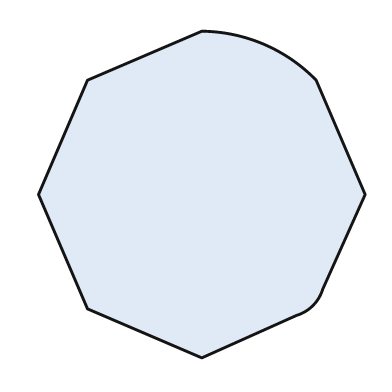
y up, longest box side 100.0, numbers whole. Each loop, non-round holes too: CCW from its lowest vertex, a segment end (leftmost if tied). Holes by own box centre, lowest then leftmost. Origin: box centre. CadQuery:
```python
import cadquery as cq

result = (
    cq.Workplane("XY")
    .moveTo(0.0, -50.0)
    .lineTo(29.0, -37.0)
    .threePointArc((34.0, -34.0), (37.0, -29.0))
    .lineTo(50.0, 0.0)
    .lineTo(35.0, 35.0)
    .threePointArc((19.0, 46.0), (0.0, 50.0))
    .lineTo(-35.0, 35.0)
    .lineTo(-50.0, 0.0)
    .lineTo(-35.0, -35.0)
    .close()
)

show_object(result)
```